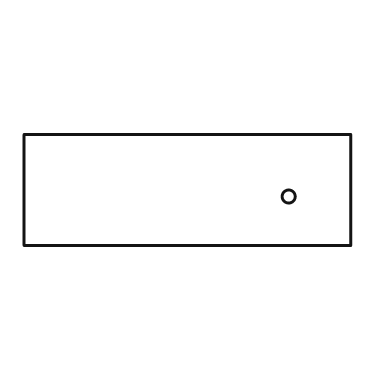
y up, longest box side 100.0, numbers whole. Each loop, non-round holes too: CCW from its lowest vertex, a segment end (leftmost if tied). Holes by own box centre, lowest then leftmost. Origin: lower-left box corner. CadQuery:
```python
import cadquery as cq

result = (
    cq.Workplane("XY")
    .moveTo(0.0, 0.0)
    .lineTo(100.0, 0.0)
    .lineTo(100.0, 34.0)
    .lineTo(0.0, 34.0)
    .close()
    .moveTo(81.0, 15.0)
    .circle(2.0)
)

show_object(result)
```